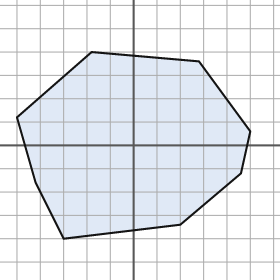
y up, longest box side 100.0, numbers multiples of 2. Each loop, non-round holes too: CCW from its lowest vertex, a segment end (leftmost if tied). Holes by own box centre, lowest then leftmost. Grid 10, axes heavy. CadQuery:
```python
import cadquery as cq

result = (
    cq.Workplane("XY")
    .moveTo(-30.0, -40.0)
    .lineTo(20.0, -34.0)
    .lineTo(46.0, -12.0)
    .lineTo(50.0, 6.0)
    .lineTo(28.0, 36.0)
    .lineTo(-18.0, 40.0)
    .lineTo(-50.0, 12.0)
    .lineTo(-42.0, -16.0)
    .close()
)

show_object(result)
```